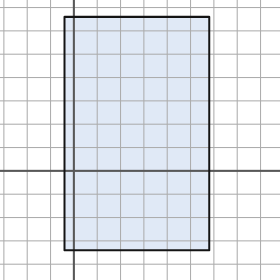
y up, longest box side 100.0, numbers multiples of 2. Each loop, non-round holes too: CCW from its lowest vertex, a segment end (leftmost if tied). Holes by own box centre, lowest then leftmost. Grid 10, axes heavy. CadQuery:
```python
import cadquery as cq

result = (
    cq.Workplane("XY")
    .moveTo(-4.0, -34.0)
    .lineTo(58.0, -34.0)
    .lineTo(58.0, 66.0)
    .lineTo(-4.0, 66.0)
    .close()
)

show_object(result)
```